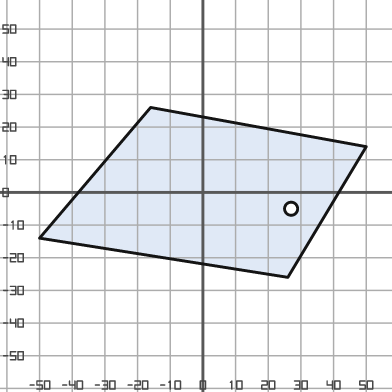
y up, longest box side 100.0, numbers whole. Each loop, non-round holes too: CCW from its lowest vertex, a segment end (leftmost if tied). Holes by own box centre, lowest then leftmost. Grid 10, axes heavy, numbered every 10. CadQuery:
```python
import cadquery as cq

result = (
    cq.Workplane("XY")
    .moveTo(26.0, -26.0)
    .lineTo(50.0, 14.0)
    .lineTo(-16.0, 26.0)
    .lineTo(-50.0, -14.0)
    .close()
    .moveTo(27.0, -5.0)
    .circle(2.0)
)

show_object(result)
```